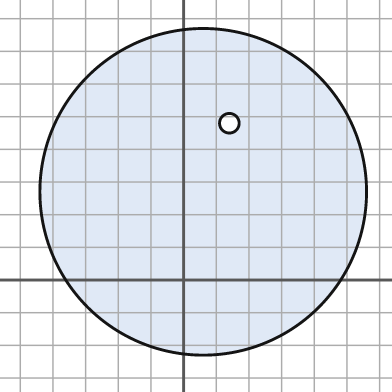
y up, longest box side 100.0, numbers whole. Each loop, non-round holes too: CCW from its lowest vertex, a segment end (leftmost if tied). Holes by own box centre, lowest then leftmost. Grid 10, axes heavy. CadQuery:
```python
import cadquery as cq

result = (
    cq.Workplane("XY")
    .moveTo(6.0, 27.0)
    .circle(50.0)
    .moveTo(14.0, 48.0)
    .circle(3.0)
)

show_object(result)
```